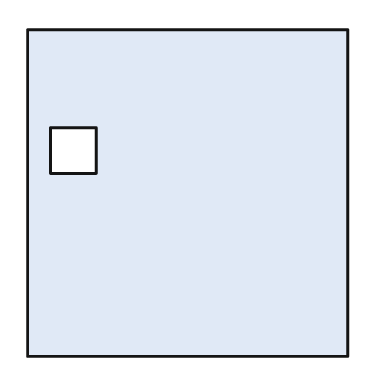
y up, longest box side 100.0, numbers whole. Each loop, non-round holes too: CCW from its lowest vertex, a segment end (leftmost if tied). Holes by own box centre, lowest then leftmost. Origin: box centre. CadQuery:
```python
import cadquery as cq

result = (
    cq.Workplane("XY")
    .moveTo(-49.0, -50.0)
    .lineTo(49.0, -50.0)
    .lineTo(49.0, 50.0)
    .lineTo(-49.0, 50.0)
    .close()
    .moveTo(-42.0, 6.0)
    .lineTo(-28.0, 6.0)
    .lineTo(-28.0, 20.0)
    .lineTo(-42.0, 20.0)
    .close()
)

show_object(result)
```